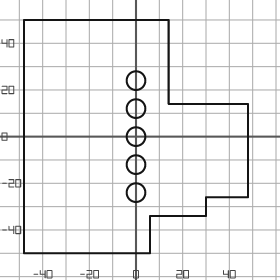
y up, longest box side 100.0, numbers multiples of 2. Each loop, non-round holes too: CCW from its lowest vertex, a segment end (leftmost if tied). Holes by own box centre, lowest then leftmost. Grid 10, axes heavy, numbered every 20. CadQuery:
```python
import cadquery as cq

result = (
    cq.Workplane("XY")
    .moveTo(-48.0, -50.0)
    .lineTo(6.0, -50.0)
    .lineTo(6.0, -34.0)
    .lineTo(30.0, -34.0)
    .lineTo(30.0, -26.0)
    .lineTo(48.0, -26.0)
    .lineTo(48.0, 14.0)
    .lineTo(14.0, 14.0)
    .lineTo(14.0, 50.0)
    .lineTo(-48.0, 50.0)
    .close()
    .moveTo(0.0, -24.0)
    .circle(4.0)
    .moveTo(0.0, -12.0)
    .circle(4.0)
    .moveTo(0.0, 0.0)
    .circle(4.0)
    .moveTo(0.0, 12.0)
    .circle(4.0)
    .moveTo(0.0, 24.0)
    .circle(4.0)
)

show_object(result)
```